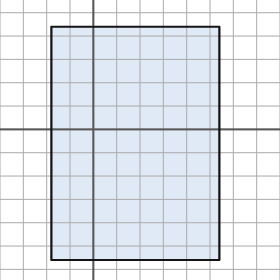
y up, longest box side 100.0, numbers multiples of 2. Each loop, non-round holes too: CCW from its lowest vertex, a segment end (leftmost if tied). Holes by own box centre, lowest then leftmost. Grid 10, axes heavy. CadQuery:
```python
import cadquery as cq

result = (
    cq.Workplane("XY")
    .moveTo(-18.0, -56.0)
    .lineTo(54.0, -56.0)
    .lineTo(54.0, 44.0)
    .lineTo(-18.0, 44.0)
    .close()
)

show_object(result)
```